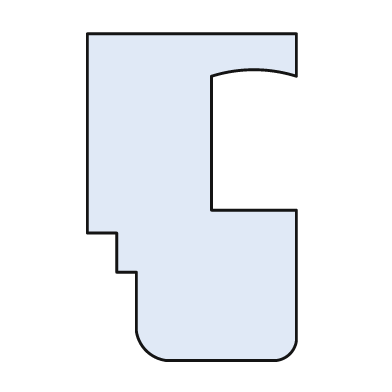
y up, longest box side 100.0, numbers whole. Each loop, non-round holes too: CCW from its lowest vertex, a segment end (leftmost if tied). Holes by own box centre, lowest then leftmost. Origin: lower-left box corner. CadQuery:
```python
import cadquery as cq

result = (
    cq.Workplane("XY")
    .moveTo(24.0, 0.0)
    .lineTo(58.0, 0.0)
    .threePointArc((62.0, 2.0), (64.0, 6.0))
    .lineTo(64.0, 46.0)
    .lineTo(38.0, 46.0)
    .lineTo(38.0, 87.0)
    .threePointArc((51.0, 89.0), (64.0, 87.0))
    .lineTo(64.0, 100.0)
    .lineTo(0.0, 100.0)
    .lineTo(0.0, 39.0)
    .lineTo(9.0, 39.0)
    .lineTo(9.0, 27.0)
    .lineTo(15.0, 27.0)
    .lineTo(15.0, 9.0)
    .threePointArc((18.0, 3.0), (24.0, 0.0))
    .close()
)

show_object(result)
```